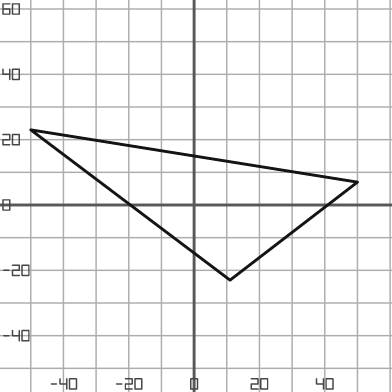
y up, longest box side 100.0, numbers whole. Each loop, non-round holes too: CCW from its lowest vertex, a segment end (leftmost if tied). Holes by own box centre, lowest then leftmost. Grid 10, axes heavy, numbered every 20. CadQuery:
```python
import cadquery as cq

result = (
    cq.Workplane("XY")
    .moveTo(11.0, -23.0)
    .lineTo(50.0, 7.0)
    .lineTo(-50.0, 23.0)
    .close()
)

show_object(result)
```